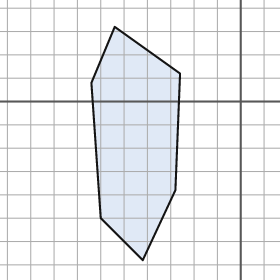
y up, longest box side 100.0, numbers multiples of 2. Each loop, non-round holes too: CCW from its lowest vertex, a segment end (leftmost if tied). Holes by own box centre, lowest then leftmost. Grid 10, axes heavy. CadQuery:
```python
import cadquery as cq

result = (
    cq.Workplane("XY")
    .moveTo(-42.0, -68.0)
    .lineTo(-28.0, -38.0)
    .lineTo(-26.0, 12.0)
    .lineTo(-54.0, 32.0)
    .lineTo(-64.0, 8.0)
    .lineTo(-60.0, -50.0)
    .close()
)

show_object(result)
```